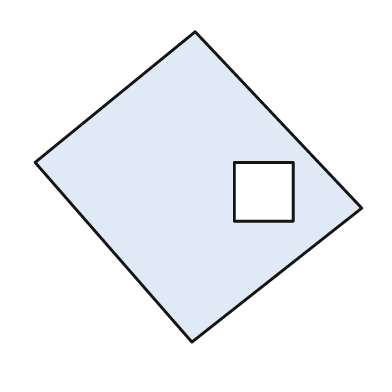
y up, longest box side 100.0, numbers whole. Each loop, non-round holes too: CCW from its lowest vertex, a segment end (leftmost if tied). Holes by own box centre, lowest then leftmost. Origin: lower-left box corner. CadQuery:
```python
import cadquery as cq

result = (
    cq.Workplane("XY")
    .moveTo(48.0, 0.0)
    .lineTo(100.0, 41.0)
    .lineTo(49.0, 95.0)
    .lineTo(0.0, 55.0)
    .close()
    .moveTo(61.0, 37.0)
    .lineTo(79.0, 37.0)
    .lineTo(79.0, 55.0)
    .lineTo(61.0, 55.0)
    .close()
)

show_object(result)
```